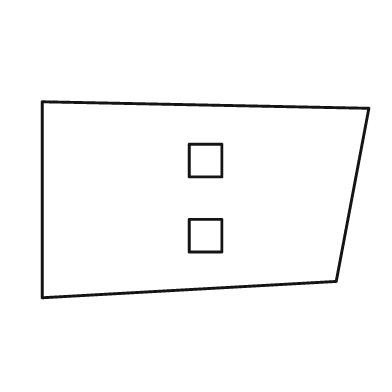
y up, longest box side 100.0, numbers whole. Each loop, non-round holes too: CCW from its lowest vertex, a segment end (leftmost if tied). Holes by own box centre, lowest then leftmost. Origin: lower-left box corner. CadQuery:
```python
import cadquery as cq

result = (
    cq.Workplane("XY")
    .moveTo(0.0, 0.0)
    .lineTo(90.0, 5.0)
    .lineTo(100.0, 58.0)
    .lineTo(0.0, 60.0)
    .close()
    .moveTo(45.0, 14.0)
    .lineTo(55.0, 14.0)
    .lineTo(55.0, 24.0)
    .lineTo(45.0, 24.0)
    .close()
    .moveTo(45.0, 37.0)
    .lineTo(55.0, 37.0)
    .lineTo(55.0, 47.0)
    .lineTo(45.0, 47.0)
    .close()
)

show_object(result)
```